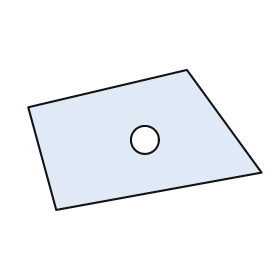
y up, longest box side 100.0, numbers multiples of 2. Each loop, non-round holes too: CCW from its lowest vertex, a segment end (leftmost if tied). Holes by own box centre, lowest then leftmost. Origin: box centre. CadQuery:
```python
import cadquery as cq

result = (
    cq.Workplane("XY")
    .moveTo(-38.0, -30.0)
    .lineTo(50.0, -14.0)
    .lineTo(18.0, 30.0)
    .lineTo(-50.0, 14.0)
    .close()
    .moveTo(0.0, 0.0)
    .circle(6.0)
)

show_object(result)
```